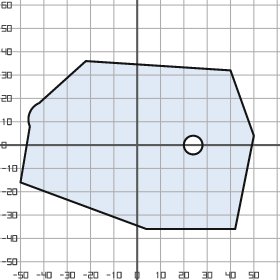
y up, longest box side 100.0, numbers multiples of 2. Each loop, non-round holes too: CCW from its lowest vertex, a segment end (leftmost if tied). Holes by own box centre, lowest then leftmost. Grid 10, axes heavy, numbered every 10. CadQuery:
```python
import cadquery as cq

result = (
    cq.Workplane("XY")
    .moveTo(4.0, -36.0)
    .lineTo(42.0, -36.0)
    .lineTo(50.0, 4.0)
    .lineTo(40.0, 32.0)
    .lineTo(-22.0, 36.0)
    .lineTo(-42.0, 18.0)
    .threePointArc((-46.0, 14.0), (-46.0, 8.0))
    .lineTo(-50.0, -16.0)
    .close()
    .moveTo(24.0, 0.0)
    .circle(4.0)
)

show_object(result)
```